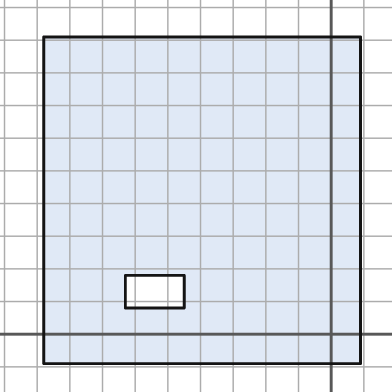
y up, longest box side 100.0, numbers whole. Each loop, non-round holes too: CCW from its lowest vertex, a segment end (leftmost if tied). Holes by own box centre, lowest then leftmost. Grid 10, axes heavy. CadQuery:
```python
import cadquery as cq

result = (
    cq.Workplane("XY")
    .moveTo(-88.0, -9.0)
    .lineTo(9.0, -9.0)
    .lineTo(9.0, 91.0)
    .lineTo(-88.0, 91.0)
    .close()
    .moveTo(-63.0, 8.0)
    .lineTo(-45.0, 8.0)
    .lineTo(-45.0, 18.0)
    .lineTo(-63.0, 18.0)
    .close()
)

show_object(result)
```